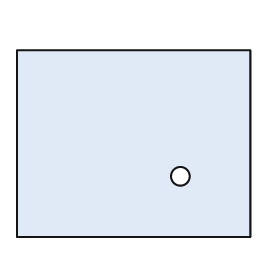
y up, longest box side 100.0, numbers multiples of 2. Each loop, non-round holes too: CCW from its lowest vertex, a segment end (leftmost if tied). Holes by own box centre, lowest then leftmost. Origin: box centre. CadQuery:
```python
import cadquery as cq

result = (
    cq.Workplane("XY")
    .moveTo(-50.0, -40.0)
    .lineTo(50.0, -40.0)
    .lineTo(50.0, 40.0)
    .lineTo(-50.0, 40.0)
    .close()
    .moveTo(20.0, -14.0)
    .circle(4.0)
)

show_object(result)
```